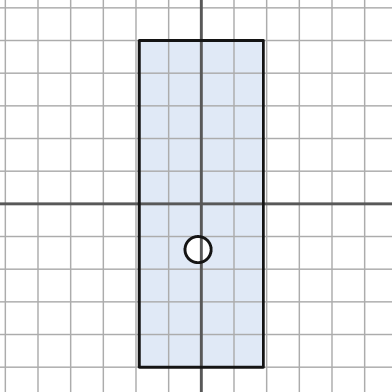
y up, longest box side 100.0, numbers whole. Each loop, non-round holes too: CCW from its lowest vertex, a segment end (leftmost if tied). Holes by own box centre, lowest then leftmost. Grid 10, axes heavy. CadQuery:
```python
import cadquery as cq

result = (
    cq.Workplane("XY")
    .moveTo(-19.0, -50.0)
    .lineTo(19.0, -50.0)
    .lineTo(19.0, 50.0)
    .lineTo(-19.0, 50.0)
    .close()
    .moveTo(-1.0, -14.0)
    .circle(4.0)
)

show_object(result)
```